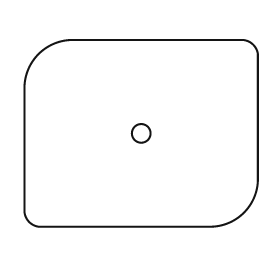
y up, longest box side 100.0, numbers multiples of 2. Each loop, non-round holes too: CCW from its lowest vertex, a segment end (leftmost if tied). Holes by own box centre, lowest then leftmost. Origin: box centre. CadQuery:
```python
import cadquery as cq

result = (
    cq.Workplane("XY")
    .moveTo(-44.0, -40.0)
    .lineTo(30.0, -40.0)
    .threePointArc((44.0, -34.0), (50.0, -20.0))
    .lineTo(50.0, 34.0)
    .threePointArc((48.0, 38.0), (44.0, 40.0))
    .lineTo(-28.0, 40.0)
    .threePointArc((-44.0, 34.0), (-50.0, 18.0))
    .lineTo(-50.0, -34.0)
    .threePointArc((-48.0, -38.0), (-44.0, -40.0))
    .close()
    .moveTo(0.0, 0.0)
    .circle(4.0)
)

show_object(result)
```